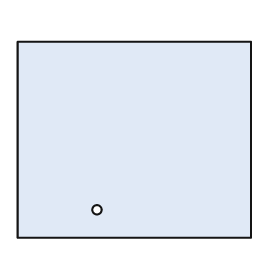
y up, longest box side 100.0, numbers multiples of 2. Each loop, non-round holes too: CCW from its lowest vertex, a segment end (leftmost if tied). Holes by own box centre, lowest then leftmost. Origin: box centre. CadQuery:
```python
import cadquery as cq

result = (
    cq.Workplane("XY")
    .moveTo(-50.0, -42.0)
    .lineTo(50.0, -42.0)
    .lineTo(50.0, 42.0)
    .lineTo(-50.0, 42.0)
    .close()
    .moveTo(-16.0, -30.0)
    .circle(2.0)
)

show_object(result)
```